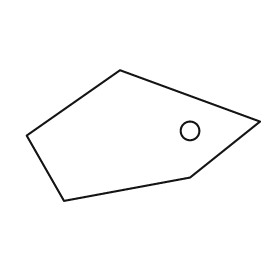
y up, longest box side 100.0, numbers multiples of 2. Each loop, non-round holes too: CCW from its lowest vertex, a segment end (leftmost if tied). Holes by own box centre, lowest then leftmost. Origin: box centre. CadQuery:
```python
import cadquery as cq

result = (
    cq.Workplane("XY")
    .moveTo(-34.0, -28.0)
    .lineTo(20.0, -18.0)
    .lineTo(50.0, 6.0)
    .lineTo(-10.0, 28.0)
    .lineTo(-50.0, 0.0)
    .close()
    .moveTo(20.0, 2.0)
    .circle(4.0)
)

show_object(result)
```